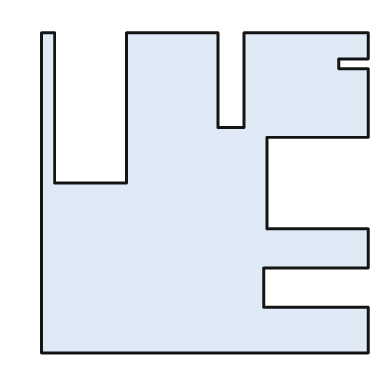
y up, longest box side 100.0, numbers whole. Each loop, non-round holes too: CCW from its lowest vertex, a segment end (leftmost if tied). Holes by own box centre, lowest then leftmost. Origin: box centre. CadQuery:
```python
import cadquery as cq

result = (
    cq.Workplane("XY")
    .moveTo(-50.0, -49.0)
    .lineTo(50.0, -49.0)
    .lineTo(50.0, -35.0)
    .lineTo(18.0, -35.0)
    .lineTo(18.0, -23.0)
    .lineTo(50.0, -23.0)
    .lineTo(50.0, -11.0)
    .lineTo(19.0, -11.0)
    .lineTo(19.0, 17.0)
    .lineTo(50.0, 17.0)
    .lineTo(50.0, 38.0)
    .lineTo(41.0, 38.0)
    .lineTo(41.0, 41.0)
    .lineTo(50.0, 41.0)
    .lineTo(50.0, 49.0)
    .lineTo(12.0, 49.0)
    .lineTo(12.0, 20.0)
    .lineTo(4.0, 20.0)
    .lineTo(4.0, 49.0)
    .lineTo(-24.0, 49.0)
    .lineTo(-24.0, 3.0)
    .lineTo(-46.0, 3.0)
    .lineTo(-46.0, 49.0)
    .lineTo(-50.0, 49.0)
    .close()
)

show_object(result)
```